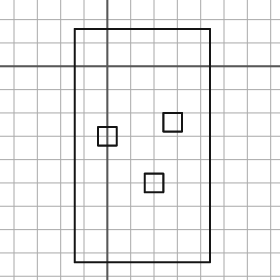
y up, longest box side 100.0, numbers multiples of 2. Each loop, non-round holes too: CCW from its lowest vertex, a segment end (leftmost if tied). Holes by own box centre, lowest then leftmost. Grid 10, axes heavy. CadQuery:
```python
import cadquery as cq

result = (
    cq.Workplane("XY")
    .moveTo(-14.0, -84.0)
    .lineTo(44.0, -84.0)
    .lineTo(44.0, 16.0)
    .lineTo(-14.0, 16.0)
    .close()
    .moveTo(16.0, -54.0)
    .lineTo(24.0, -54.0)
    .lineTo(24.0, -46.0)
    .lineTo(16.0, -46.0)
    .close()
    .moveTo(-4.0, -34.0)
    .lineTo(4.0, -34.0)
    .lineTo(4.0, -26.0)
    .lineTo(-4.0, -26.0)
    .close()
    .moveTo(24.0, -28.0)
    .lineTo(32.0, -28.0)
    .lineTo(32.0, -20.0)
    .lineTo(24.0, -20.0)
    .close()
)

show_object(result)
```